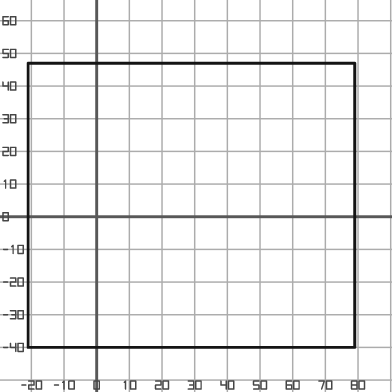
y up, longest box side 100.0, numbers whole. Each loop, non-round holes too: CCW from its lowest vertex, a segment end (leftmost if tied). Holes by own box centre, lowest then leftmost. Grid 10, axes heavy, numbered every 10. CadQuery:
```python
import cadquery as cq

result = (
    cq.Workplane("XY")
    .moveTo(-21.0, -40.0)
    .lineTo(79.0, -40.0)
    .lineTo(79.0, 47.0)
    .lineTo(-21.0, 47.0)
    .close()
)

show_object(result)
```